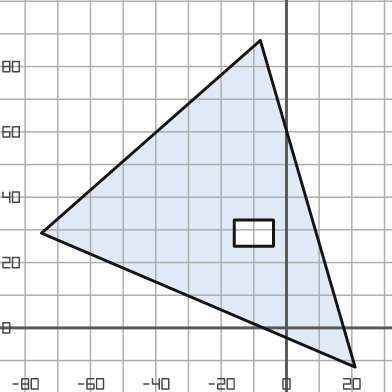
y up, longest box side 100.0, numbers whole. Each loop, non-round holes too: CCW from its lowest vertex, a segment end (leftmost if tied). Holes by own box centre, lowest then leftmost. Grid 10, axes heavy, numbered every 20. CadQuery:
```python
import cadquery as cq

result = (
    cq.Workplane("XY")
    .moveTo(21.0, -12.0)
    .lineTo(-8.0, 88.0)
    .lineTo(-75.0, 29.0)
    .close()
    .moveTo(-16.0, 25.0)
    .lineTo(-4.0, 25.0)
    .lineTo(-4.0, 33.0)
    .lineTo(-16.0, 33.0)
    .close()
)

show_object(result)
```